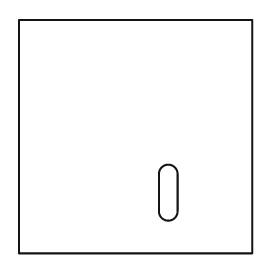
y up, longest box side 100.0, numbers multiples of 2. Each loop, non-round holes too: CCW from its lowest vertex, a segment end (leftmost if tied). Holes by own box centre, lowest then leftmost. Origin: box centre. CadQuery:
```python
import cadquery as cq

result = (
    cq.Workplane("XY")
    .moveTo(-50.0, -50.0)
    .lineTo(50.0, -50.0)
    .lineTo(50.0, 50.0)
    .lineTo(-50.0, 50.0)
    .close()
    .moveTo(10.0, -32.0)
    .threePointArc((14.0, -36.0), (18.0, -32.0))
    .lineTo(18.0, -16.0)
    .threePointArc((14.0, -12.0), (10.0, -16.0))
    .close()
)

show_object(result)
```